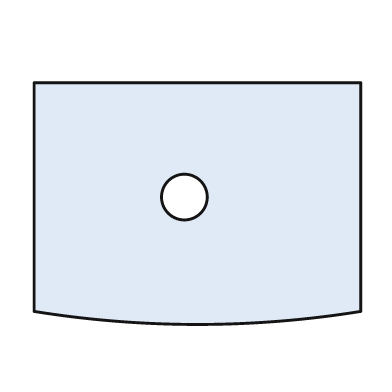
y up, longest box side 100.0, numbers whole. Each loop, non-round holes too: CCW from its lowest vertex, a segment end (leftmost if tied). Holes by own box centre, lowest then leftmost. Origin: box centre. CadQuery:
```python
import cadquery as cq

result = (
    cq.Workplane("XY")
    .moveTo(-50.0, -33.0)
    .threePointArc((0.0, -37.0), (50.0, -33.0))
    .lineTo(50.0, 37.0)
    .lineTo(-50.0, 37.0)
    .close()
    .moveTo(-4.0, 2.0)
    .circle(7.0)
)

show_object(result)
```